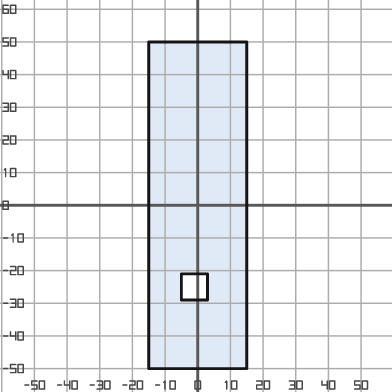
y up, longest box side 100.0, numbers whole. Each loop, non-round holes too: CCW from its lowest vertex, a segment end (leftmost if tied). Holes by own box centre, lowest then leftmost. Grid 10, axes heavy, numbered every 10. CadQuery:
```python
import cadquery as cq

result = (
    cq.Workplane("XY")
    .moveTo(-15.0, -50.0)
    .lineTo(15.0, -50.0)
    .lineTo(15.0, 50.0)
    .lineTo(-15.0, 50.0)
    .close()
    .moveTo(-5.0, -29.0)
    .lineTo(3.0, -29.0)
    .lineTo(3.0, -21.0)
    .lineTo(-5.0, -21.0)
    .close()
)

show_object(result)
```